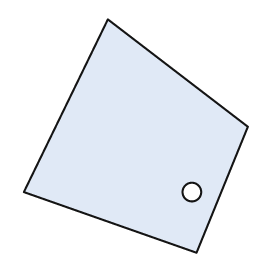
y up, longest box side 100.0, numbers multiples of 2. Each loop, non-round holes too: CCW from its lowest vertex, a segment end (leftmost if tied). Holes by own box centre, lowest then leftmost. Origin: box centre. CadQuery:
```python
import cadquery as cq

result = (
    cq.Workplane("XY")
    .moveTo(26.0, -50.0)
    .lineTo(48.0, 4.0)
    .lineTo(-12.0, 50.0)
    .lineTo(-48.0, -24.0)
    .close()
    .moveTo(24.0, -24.0)
    .circle(4.0)
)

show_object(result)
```